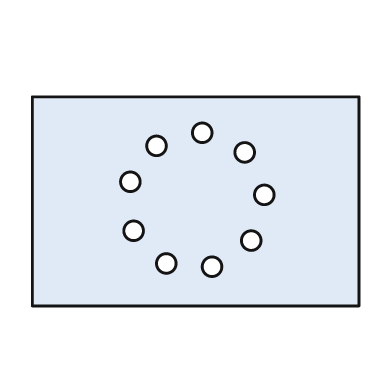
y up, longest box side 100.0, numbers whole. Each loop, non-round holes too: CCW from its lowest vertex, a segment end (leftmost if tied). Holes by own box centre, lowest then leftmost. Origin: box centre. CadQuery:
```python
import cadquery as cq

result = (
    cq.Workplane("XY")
    .moveTo(-50.0, -32.0)
    .lineTo(50.0, -32.0)
    .lineTo(50.0, 32.0)
    .lineTo(-50.0, 32.0)
    .close()
    .moveTo(5.0, -20.0)
    .circle(3.0)
    .moveTo(-9.0, -19.0)
    .circle(3.0)
    .moveTo(17.0, -12.0)
    .circle(3.0)
    .moveTo(-19.0, -9.0)
    .circle(3.0)
    .moveTo(21.0, 2.0)
    .circle(3.0)
    .moveTo(-20.0, 6.0)
    .circle(3.0)
    .moveTo(15.0, 15.0)
    .circle(3.0)
    .moveTo(-12.0, 17.0)
    .circle(3.0)
    .moveTo(2.0, 21.0)
    .circle(3.0)
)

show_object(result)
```